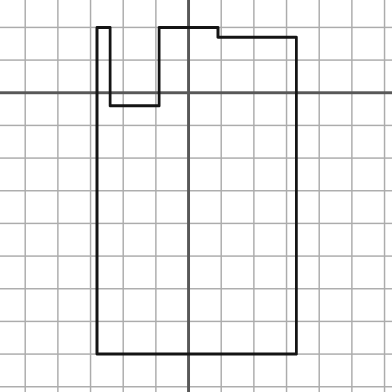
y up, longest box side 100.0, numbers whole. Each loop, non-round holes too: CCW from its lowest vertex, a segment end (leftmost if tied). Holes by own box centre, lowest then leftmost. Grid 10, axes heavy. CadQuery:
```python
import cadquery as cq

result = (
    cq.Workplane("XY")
    .moveTo(-28.0, -80.0)
    .lineTo(33.0, -80.0)
    .lineTo(33.0, 17.0)
    .lineTo(9.0, 17.0)
    .lineTo(9.0, 20.0)
    .lineTo(-9.0, 20.0)
    .lineTo(-9.0, -4.0)
    .lineTo(-24.0, -4.0)
    .lineTo(-24.0, 20.0)
    .lineTo(-28.0, 20.0)
    .close()
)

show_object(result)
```